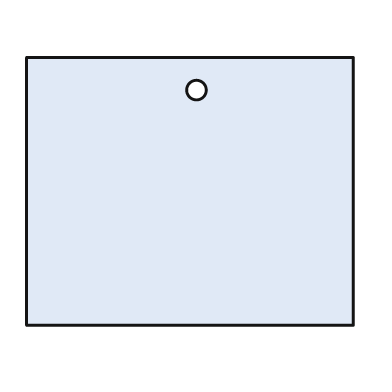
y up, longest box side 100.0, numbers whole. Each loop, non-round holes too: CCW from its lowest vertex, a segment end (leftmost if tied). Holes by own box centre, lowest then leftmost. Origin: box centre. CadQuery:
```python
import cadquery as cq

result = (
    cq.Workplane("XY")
    .moveTo(-50.0, -41.0)
    .lineTo(50.0, -41.0)
    .lineTo(50.0, 41.0)
    .lineTo(-50.0, 41.0)
    .close()
    .moveTo(2.0, 31.0)
    .circle(3.0)
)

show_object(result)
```